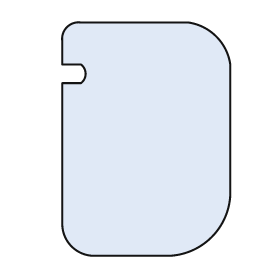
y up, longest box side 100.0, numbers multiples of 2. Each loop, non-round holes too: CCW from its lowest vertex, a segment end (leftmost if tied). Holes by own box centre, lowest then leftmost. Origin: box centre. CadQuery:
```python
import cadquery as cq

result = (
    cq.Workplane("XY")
    .moveTo(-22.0, -50.0)
    .lineTo(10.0, -50.0)
    .threePointArc((28.0, -42.0), (36.0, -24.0))
    .lineTo(36.0, 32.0)
    .threePointArc((30.0, 44.0), (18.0, 50.0))
    .lineTo(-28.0, 50.0)
    .threePointArc((-34.0, 48.0), (-36.0, 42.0))
    .lineTo(-36.0, 32.0)
    .lineTo(-28.0, 32.0)
    .threePointArc((-26.0, 28.0), (-28.0, 24.0))
    .lineTo(-36.0, 24.0)
    .lineTo(-36.0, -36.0)
    .threePointArc((-32.0, -46.0), (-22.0, -50.0))
    .close()
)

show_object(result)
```